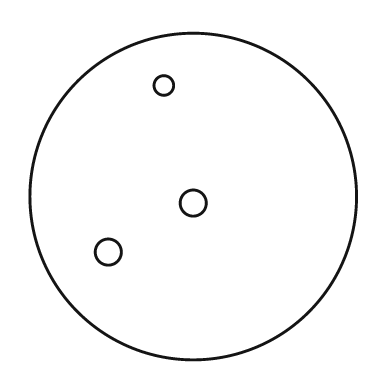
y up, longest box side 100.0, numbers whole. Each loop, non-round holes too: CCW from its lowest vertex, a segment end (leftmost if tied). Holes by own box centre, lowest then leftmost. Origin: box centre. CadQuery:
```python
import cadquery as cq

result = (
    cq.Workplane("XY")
    .moveTo(0.0, 0.0)
    .circle(50.0)
    .moveTo(-26.0, -17.0)
    .circle(4.0)
    .moveTo(0.0, -2.0)
    .circle(4.0)
    .moveTo(-9.0, 34.0)
    .circle(3.0)
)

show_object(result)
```